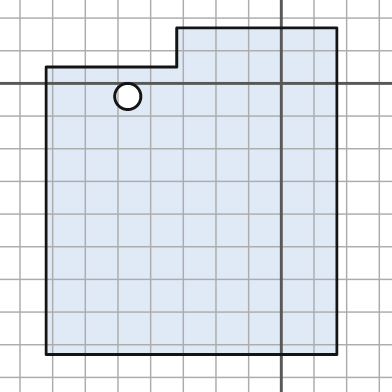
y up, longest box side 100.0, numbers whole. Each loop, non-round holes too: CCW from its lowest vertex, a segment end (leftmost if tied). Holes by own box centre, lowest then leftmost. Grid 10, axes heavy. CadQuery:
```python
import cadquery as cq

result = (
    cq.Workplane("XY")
    .moveTo(-72.0, -83.0)
    .lineTo(17.0, -83.0)
    .lineTo(17.0, 17.0)
    .lineTo(-32.0, 17.0)
    .lineTo(-32.0, 5.0)
    .lineTo(-72.0, 5.0)
    .close()
    .moveTo(-47.0, -4.0)
    .circle(4.0)
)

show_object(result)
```